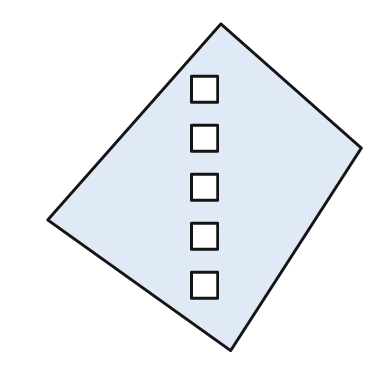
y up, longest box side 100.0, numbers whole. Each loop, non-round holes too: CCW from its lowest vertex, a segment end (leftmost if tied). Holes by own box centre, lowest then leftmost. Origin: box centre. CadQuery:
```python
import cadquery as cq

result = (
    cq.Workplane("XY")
    .moveTo(8.0, -50.0)
    .lineTo(48.0, 12.0)
    .lineTo(5.0, 50.0)
    .lineTo(-48.0, -10.0)
    .close()
    .moveTo(-4.0, -34.0)
    .lineTo(4.0, -34.0)
    .lineTo(4.0, -26.0)
    .lineTo(-4.0, -26.0)
    .close()
    .moveTo(-4.0, -19.0)
    .lineTo(4.0, -19.0)
    .lineTo(4.0, -11.0)
    .lineTo(-4.0, -11.0)
    .close()
    .moveTo(-4.0, -4.0)
    .lineTo(4.0, -4.0)
    .lineTo(4.0, 4.0)
    .lineTo(-4.0, 4.0)
    .close()
    .moveTo(-4.0, 11.0)
    .lineTo(4.0, 11.0)
    .lineTo(4.0, 19.0)
    .lineTo(-4.0, 19.0)
    .close()
    .moveTo(-4.0, 26.0)
    .lineTo(4.0, 26.0)
    .lineTo(4.0, 34.0)
    .lineTo(-4.0, 34.0)
    .close()
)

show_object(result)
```